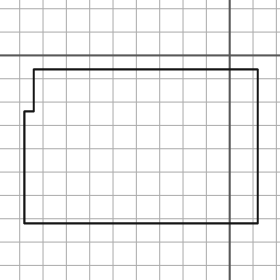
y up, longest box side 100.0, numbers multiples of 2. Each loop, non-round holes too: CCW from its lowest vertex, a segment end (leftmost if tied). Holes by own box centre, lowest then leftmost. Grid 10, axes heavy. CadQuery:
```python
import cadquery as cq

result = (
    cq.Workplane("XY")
    .moveTo(-88.0, -72.0)
    .lineTo(12.0, -72.0)
    .lineTo(12.0, -6.0)
    .lineTo(-84.0, -6.0)
    .lineTo(-84.0, -24.0)
    .lineTo(-88.0, -24.0)
    .close()
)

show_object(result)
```